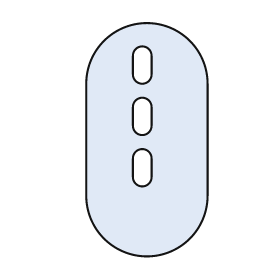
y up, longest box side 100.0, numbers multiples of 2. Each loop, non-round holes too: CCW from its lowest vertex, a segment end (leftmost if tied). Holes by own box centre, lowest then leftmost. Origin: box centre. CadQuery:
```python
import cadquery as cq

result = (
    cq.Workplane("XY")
    .moveTo(-26.0, -24.0)
    .threePointArc((0.0, -50.0), (26.0, -24.0))
    .lineTo(26.0, 24.0)
    .threePointArc((0.0, 50.0), (-26.0, 24.0))
    .close()
    .moveTo(-6.0, -16.0)
    .threePointArc((-2.0, -20.0), (2.0, -16.0))
    .lineTo(2.0, -8.0)
    .threePointArc((-2.0, -4.0), (-6.0, -8.0))
    .close()
    .moveTo(-6.0, 6.0)
    .threePointArc((-2.0, 2.0), (2.0, 6.0))
    .lineTo(2.0, 14.0)
    .threePointArc((-2.0, 18.0), (-6.0, 14.0))
    .close()
    .moveTo(-6.0, 28.0)
    .threePointArc((-2.0, 24.0), (2.0, 28.0))
    .lineTo(2.0, 36.0)
    .threePointArc((-2.0, 40.0), (-6.0, 36.0))
    .close()
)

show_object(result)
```